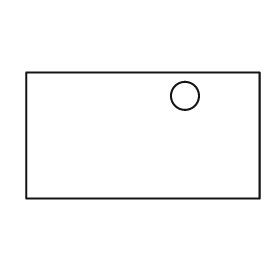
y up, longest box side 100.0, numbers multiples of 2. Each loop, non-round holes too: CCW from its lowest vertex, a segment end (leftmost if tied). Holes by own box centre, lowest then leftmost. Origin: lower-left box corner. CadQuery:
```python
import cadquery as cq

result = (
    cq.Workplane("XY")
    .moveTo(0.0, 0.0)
    .lineTo(100.0, 0.0)
    .lineTo(100.0, 54.0)
    .lineTo(0.0, 54.0)
    .close()
    .moveTo(68.0, 44.0)
    .circle(6.0)
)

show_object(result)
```